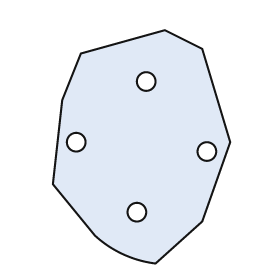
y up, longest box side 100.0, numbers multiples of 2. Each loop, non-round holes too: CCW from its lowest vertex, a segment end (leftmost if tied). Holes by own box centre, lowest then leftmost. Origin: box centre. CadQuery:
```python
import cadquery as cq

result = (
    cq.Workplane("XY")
    .moveTo(6.0, -50.0)
    .lineTo(26.0, -32.0)
    .lineTo(38.0, 2.0)
    .lineTo(26.0, 42.0)
    .lineTo(10.0, 50.0)
    .lineTo(-26.0, 40.0)
    .lineTo(-34.0, 20.0)
    .lineTo(-38.0, -16.0)
    .lineTo(-20.0, -38.0)
    .threePointArc((-8.0, -46.0), (6.0, -50.0))
    .close()
    .moveTo(-2.0, -28.0)
    .circle(4.0)
    .moveTo(28.0, -2.0)
    .circle(4.0)
    .moveTo(-28.0, 2.0)
    .circle(4.0)
    .moveTo(2.0, 28.0)
    .circle(4.0)
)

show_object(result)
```